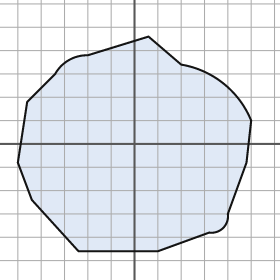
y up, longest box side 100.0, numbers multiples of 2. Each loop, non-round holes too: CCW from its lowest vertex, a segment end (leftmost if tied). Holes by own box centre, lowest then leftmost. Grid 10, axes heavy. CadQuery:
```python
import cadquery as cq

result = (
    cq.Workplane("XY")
    .moveTo(-24.0, -46.0)
    .lineTo(10.0, -46.0)
    .lineTo(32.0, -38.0)
    .threePointArc((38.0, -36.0), (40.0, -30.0))
    .lineTo(48.0, -8.0)
    .lineTo(50.0, 10.0)
    .threePointArc((38.0, 26.0), (20.0, 34.0))
    .lineTo(6.0, 46.0)
    .lineTo(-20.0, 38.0)
    .threePointArc((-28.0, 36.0), (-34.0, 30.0))
    .lineTo(-46.0, 18.0)
    .lineTo(-50.0, -8.0)
    .lineTo(-44.0, -24.0)
    .close()
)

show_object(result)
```